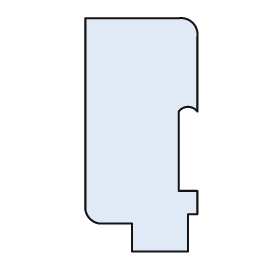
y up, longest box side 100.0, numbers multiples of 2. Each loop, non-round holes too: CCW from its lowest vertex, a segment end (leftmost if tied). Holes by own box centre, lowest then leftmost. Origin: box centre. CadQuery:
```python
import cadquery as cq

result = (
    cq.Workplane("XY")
    .moveTo(-4.0, -50.0)
    .lineTo(20.0, -50.0)
    .lineTo(20.0, -34.0)
    .lineTo(24.0, -34.0)
    .lineTo(24.0, -24.0)
    .lineTo(16.0, -24.0)
    .lineTo(16.0, 10.0)
    .threePointArc((20.0, 12.0), (24.0, 10.0))
    .lineTo(24.0, 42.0)
    .threePointArc((22.0, 48.0), (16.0, 50.0))
    .lineTo(-24.0, 50.0)
    .lineTo(-24.0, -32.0)
    .threePointArc((-22.0, -36.0), (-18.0, -38.0))
    .lineTo(-4.0, -38.0)
    .close()
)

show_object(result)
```